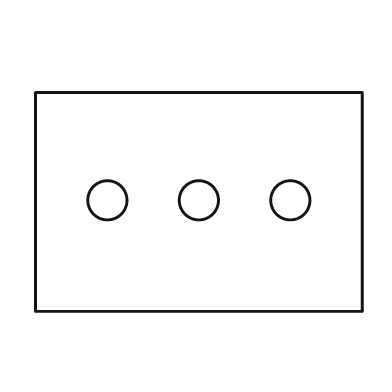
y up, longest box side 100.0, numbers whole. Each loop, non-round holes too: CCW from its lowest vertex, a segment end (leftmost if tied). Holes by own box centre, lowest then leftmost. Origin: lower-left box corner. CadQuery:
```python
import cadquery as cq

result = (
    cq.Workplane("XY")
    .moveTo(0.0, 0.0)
    .lineTo(100.0, 0.0)
    .lineTo(100.0, 67.0)
    .lineTo(0.0, 67.0)
    .close()
    .moveTo(22.0, 34.0)
    .circle(6.0)
    .moveTo(50.0, 34.0)
    .circle(6.0)
    .moveTo(78.0, 34.0)
    .circle(6.0)
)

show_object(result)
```